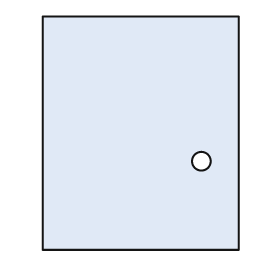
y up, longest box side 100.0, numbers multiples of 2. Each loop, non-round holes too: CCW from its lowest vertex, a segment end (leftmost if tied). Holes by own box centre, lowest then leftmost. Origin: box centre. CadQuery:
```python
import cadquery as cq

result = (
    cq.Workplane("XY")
    .moveTo(-42.0, -50.0)
    .lineTo(42.0, -50.0)
    .lineTo(42.0, 50.0)
    .lineTo(-42.0, 50.0)
    .close()
    .moveTo(26.0, -12.0)
    .circle(4.0)
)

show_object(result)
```